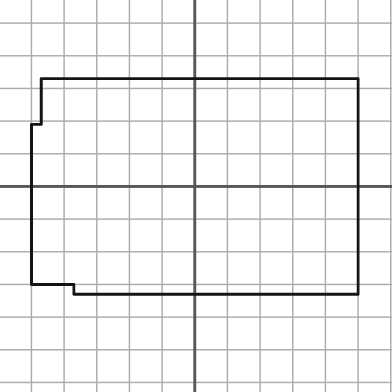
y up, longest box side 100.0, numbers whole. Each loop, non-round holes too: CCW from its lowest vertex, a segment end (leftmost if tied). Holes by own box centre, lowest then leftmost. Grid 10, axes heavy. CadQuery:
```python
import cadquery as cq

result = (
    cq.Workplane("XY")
    .moveTo(-37.0, -33.0)
    .lineTo(50.0, -33.0)
    .lineTo(50.0, 33.0)
    .lineTo(-47.0, 33.0)
    .lineTo(-47.0, 19.0)
    .lineTo(-50.0, 19.0)
    .lineTo(-50.0, -30.0)
    .lineTo(-37.0, -30.0)
    .close()
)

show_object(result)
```